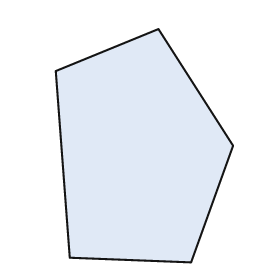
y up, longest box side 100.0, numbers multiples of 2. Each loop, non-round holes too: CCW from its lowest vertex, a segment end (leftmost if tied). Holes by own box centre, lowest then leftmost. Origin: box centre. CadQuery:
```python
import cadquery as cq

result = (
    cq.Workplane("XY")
    .moveTo(20.0, -50.0)
    .lineTo(38.0, 0.0)
    .lineTo(6.0, 50.0)
    .lineTo(-38.0, 32.0)
    .lineTo(-32.0, -48.0)
    .close()
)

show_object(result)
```